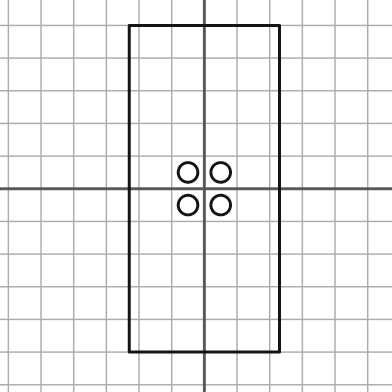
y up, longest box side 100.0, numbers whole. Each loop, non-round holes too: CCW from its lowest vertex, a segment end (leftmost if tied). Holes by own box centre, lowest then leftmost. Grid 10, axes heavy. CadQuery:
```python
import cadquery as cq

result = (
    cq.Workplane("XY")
    .moveTo(-23.0, -50.0)
    .lineTo(23.0, -50.0)
    .lineTo(23.0, 50.0)
    .lineTo(-23.0, 50.0)
    .close()
    .moveTo(-5.0, -5.0)
    .circle(3.0)
    .moveTo(5.0, -5.0)
    .circle(3.0)
    .moveTo(-5.0, 5.0)
    .circle(3.0)
    .moveTo(5.0, 5.0)
    .circle(3.0)
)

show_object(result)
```